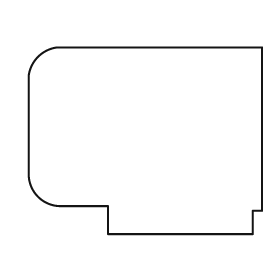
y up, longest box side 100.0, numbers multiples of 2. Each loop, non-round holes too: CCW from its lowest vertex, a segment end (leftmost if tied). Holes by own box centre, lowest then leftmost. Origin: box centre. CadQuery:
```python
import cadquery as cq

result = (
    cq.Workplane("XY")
    .moveTo(-16.0, -40.0)
    .lineTo(46.0, -40.0)
    .lineTo(46.0, -30.0)
    .lineTo(50.0, -30.0)
    .lineTo(50.0, 40.0)
    .lineTo(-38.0, 40.0)
    .threePointArc((-46.0, 36.0), (-50.0, 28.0))
    .lineTo(-50.0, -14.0)
    .threePointArc((-46.0, -24.0), (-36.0, -28.0))
    .lineTo(-16.0, -28.0)
    .close()
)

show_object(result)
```